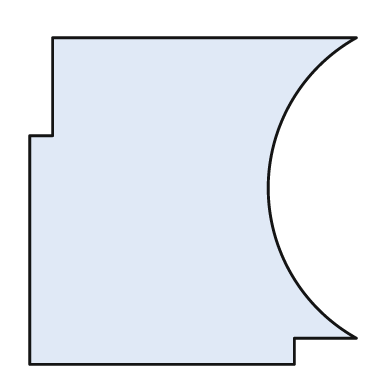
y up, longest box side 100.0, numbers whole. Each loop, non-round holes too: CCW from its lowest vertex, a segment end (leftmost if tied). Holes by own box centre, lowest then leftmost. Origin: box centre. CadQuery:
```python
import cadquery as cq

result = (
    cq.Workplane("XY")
    .moveTo(-50.0, -50.0)
    .lineTo(31.0, -50.0)
    .lineTo(31.0, -42.0)
    .lineTo(50.0, -42.0)
    .threePointArc((23.0, 4.0), (50.0, 50.0))
    .lineTo(-43.0, 50.0)
    .lineTo(-43.0, 20.0)
    .lineTo(-50.0, 20.0)
    .close()
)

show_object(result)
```